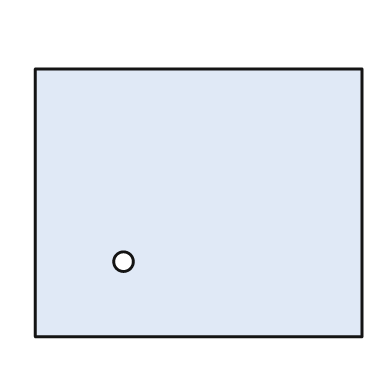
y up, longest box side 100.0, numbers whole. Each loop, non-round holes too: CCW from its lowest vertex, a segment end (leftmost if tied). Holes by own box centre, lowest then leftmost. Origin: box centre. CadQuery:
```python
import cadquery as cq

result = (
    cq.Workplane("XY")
    .moveTo(-50.0, -41.0)
    .lineTo(50.0, -41.0)
    .lineTo(50.0, 41.0)
    .lineTo(-50.0, 41.0)
    .close()
    .moveTo(-23.0, -18.0)
    .circle(3.0)
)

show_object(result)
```